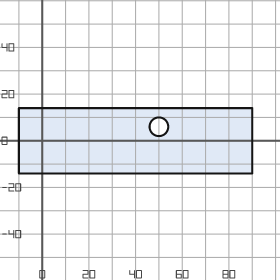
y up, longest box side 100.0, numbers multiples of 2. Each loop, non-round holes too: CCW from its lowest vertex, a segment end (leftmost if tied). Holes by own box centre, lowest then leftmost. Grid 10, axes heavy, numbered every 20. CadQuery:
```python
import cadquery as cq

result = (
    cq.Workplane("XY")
    .moveTo(-10.0, -14.0)
    .lineTo(90.0, -14.0)
    .lineTo(90.0, 14.0)
    .lineTo(-10.0, 14.0)
    .close()
    .moveTo(50.0, 6.0)
    .circle(4.0)
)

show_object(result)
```